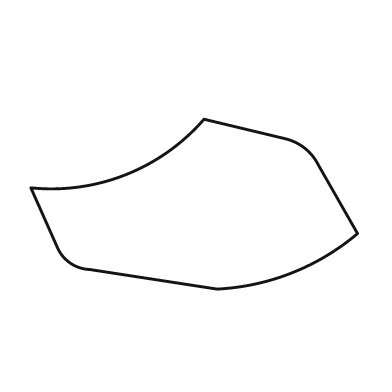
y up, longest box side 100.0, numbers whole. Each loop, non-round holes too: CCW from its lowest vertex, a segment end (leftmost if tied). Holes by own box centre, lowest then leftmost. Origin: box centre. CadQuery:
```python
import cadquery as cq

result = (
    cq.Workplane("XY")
    .moveTo(7.0, -26.0)
    .threePointArc((30.0, -21.0), (50.0, -9.0))
    .lineTo(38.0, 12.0)
    .threePointArc((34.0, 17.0), (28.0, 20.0))
    .lineTo(3.0, 26.0)
    .threePointArc((-21.0, 9.0), (-50.0, 5.0))
    .lineTo(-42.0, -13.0)
    .threePointArc((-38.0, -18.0), (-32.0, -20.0))
    .close()
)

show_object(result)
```